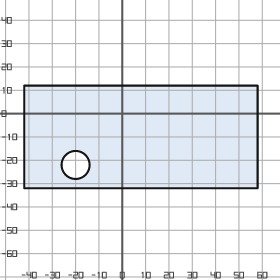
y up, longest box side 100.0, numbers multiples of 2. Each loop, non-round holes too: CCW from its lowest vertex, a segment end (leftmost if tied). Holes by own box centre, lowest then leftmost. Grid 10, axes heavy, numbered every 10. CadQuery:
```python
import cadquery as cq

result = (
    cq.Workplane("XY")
    .moveTo(-42.0, -32.0)
    .lineTo(58.0, -32.0)
    .lineTo(58.0, 12.0)
    .lineTo(-42.0, 12.0)
    .close()
    .moveTo(-20.0, -22.0)
    .circle(6.0)
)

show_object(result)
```